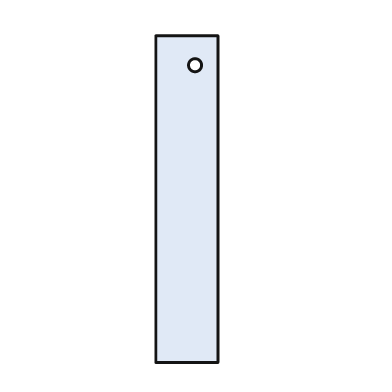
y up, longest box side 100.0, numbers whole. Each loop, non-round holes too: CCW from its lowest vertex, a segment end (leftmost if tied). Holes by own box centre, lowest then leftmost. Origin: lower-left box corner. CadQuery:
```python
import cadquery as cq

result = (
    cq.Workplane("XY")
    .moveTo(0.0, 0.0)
    .lineTo(19.0, 0.0)
    .lineTo(19.0, 100.0)
    .lineTo(0.0, 100.0)
    .close()
    .moveTo(12.0, 91.0)
    .circle(2.0)
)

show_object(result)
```